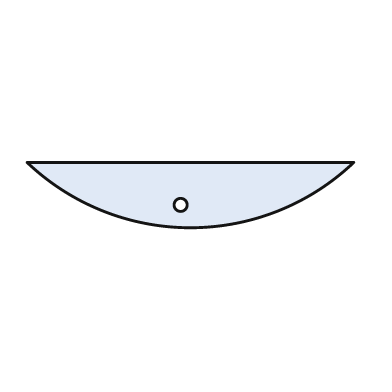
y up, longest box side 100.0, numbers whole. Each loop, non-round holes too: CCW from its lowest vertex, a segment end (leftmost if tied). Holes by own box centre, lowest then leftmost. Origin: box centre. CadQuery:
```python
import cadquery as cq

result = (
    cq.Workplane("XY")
    .moveTo(-50.0, 10.0)
    .threePointArc((0.0, -10.0), (50.0, 10.0))
    .close()
    .moveTo(-3.0, -3.0)
    .circle(2.0)
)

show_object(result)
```